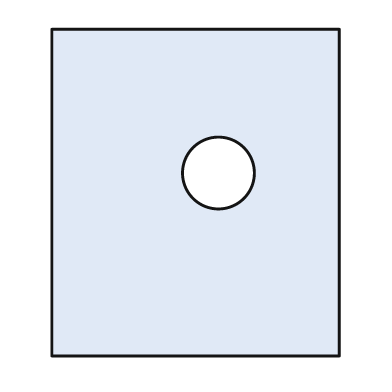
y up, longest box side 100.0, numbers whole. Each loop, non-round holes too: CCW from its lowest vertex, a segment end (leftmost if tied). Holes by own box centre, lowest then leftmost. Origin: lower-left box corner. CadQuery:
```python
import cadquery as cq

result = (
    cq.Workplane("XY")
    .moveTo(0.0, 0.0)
    .lineTo(88.0, 0.0)
    .lineTo(88.0, 100.0)
    .lineTo(0.0, 100.0)
    .close()
    .moveTo(51.0, 56.0)
    .circle(11.0)
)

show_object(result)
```